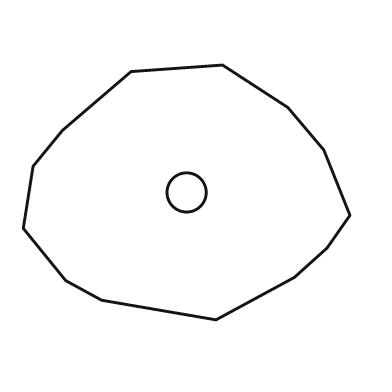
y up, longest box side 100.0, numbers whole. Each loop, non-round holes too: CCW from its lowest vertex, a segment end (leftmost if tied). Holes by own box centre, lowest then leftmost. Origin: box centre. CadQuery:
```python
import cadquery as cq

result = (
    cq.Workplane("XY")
    .moveTo(9.0, -39.0)
    .lineTo(33.0, -26.0)
    .lineTo(43.0, -17.0)
    .lineTo(50.0, -7.0)
    .lineTo(42.0, 13.0)
    .lineTo(31.0, 26.0)
    .lineTo(11.0, 39.0)
    .lineTo(-17.0, 37.0)
    .lineTo(-38.0, 19.0)
    .lineTo(-47.0, 8.0)
    .lineTo(-50.0, -11.0)
    .lineTo(-37.0, -27.0)
    .lineTo(-26.0, -33.0)
    .close()
    .moveTo(0.0, 0.0)
    .circle(6.0)
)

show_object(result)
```